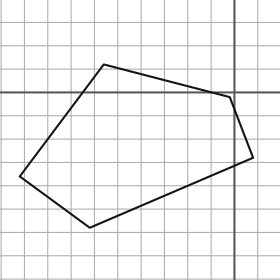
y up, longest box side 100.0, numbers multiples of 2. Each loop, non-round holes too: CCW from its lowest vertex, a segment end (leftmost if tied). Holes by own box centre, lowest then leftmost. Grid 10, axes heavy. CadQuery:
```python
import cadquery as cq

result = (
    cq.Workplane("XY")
    .moveTo(-62.0, -58.0)
    .lineTo(8.0, -28.0)
    .lineTo(-2.0, -2.0)
    .lineTo(-56.0, 12.0)
    .lineTo(-92.0, -36.0)
    .close()
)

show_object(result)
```